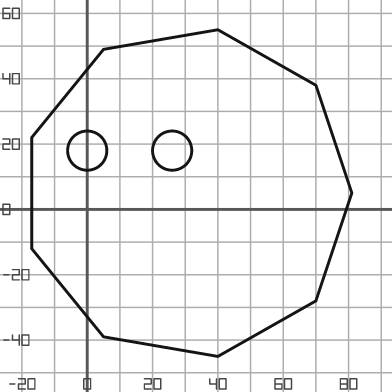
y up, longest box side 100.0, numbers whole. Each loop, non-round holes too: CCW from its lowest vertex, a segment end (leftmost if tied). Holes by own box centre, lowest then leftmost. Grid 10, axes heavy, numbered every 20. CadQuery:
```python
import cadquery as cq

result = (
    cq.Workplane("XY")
    .moveTo(40.0, -45.0)
    .lineTo(70.0, -28.0)
    .lineTo(81.0, 5.0)
    .lineTo(70.0, 38.0)
    .lineTo(40.0, 55.0)
    .lineTo(5.0, 49.0)
    .lineTo(-17.0, 22.0)
    .lineTo(-17.0, -12.0)
    .lineTo(5.0, -39.0)
    .close()
    .moveTo(0.0, 18.0)
    .circle(6.0)
    .moveTo(26.0, 18.0)
    .circle(6.0)
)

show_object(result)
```